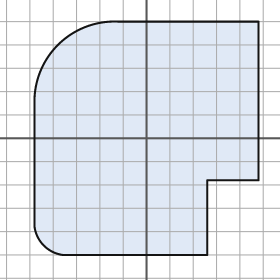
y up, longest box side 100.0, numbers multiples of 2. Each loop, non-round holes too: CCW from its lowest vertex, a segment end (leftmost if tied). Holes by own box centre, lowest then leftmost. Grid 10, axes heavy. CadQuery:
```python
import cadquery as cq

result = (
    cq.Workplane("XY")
    .moveTo(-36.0, -50.0)
    .lineTo(26.0, -50.0)
    .lineTo(26.0, -18.0)
    .lineTo(48.0, -18.0)
    .lineTo(48.0, 50.0)
    .lineTo(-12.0, 50.0)
    .threePointArc((-38.0, 40.0), (-48.0, 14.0))
    .lineTo(-48.0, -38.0)
    .threePointArc((-44.0, -46.0), (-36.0, -50.0))
    .close()
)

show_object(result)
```